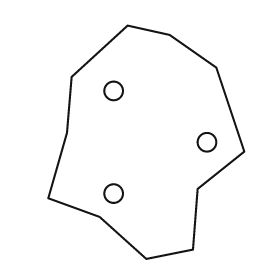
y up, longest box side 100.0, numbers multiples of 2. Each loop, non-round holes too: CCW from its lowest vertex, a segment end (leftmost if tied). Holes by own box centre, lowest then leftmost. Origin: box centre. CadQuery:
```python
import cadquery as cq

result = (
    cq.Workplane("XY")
    .moveTo(0.0, -50.0)
    .lineTo(20.0, -46.0)
    .lineTo(22.0, -20.0)
    .lineTo(42.0, -4.0)
    .lineTo(30.0, 32.0)
    .lineTo(10.0, 46.0)
    .lineTo(-8.0, 50.0)
    .lineTo(-32.0, 28.0)
    .lineTo(-34.0, 4.0)
    .lineTo(-42.0, -24.0)
    .lineTo(-20.0, -32.0)
    .close()
    .moveTo(-14.0, -22.0)
    .circle(4.0)
    .moveTo(26.0, 0.0)
    .circle(4.0)
    .moveTo(-14.0, 22.0)
    .circle(4.0)
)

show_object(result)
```